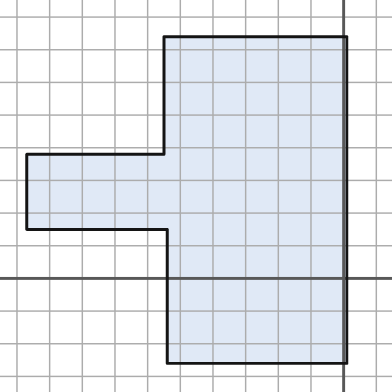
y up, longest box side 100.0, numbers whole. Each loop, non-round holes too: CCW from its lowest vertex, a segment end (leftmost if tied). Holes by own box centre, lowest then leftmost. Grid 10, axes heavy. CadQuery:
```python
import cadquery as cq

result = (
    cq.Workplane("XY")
    .moveTo(-54.0, -26.0)
    .lineTo(1.0, -26.0)
    .lineTo(1.0, 74.0)
    .lineTo(-55.0, 74.0)
    .lineTo(-55.0, 38.0)
    .lineTo(-97.0, 38.0)
    .lineTo(-97.0, 15.0)
    .lineTo(-54.0, 15.0)
    .close()
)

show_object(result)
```